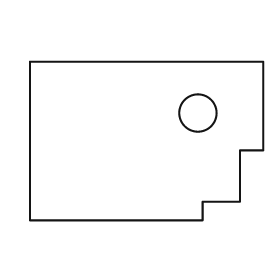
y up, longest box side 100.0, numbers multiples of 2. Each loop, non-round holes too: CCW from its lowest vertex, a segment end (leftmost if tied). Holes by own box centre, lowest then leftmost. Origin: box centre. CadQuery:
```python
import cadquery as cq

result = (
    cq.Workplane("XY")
    .moveTo(-50.0, -34.0)
    .lineTo(24.0, -34.0)
    .lineTo(24.0, -26.0)
    .lineTo(40.0, -26.0)
    .lineTo(40.0, -4.0)
    .lineTo(50.0, -4.0)
    .lineTo(50.0, 34.0)
    .lineTo(-50.0, 34.0)
    .close()
    .moveTo(22.0, 12.0)
    .circle(8.0)
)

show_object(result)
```